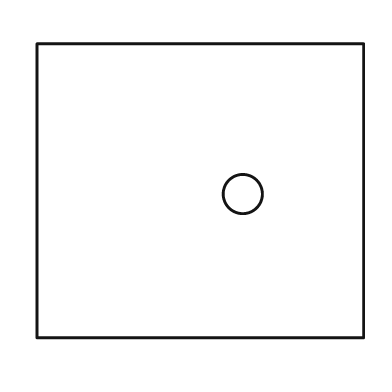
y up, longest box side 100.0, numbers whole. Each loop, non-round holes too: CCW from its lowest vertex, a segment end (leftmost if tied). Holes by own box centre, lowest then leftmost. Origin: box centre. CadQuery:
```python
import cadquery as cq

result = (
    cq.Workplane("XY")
    .moveTo(-50.0, -45.0)
    .lineTo(50.0, -45.0)
    .lineTo(50.0, 45.0)
    .lineTo(-50.0, 45.0)
    .close()
    .moveTo(13.0, -1.0)
    .circle(6.0)
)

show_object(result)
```